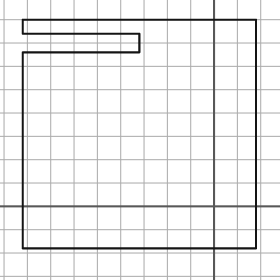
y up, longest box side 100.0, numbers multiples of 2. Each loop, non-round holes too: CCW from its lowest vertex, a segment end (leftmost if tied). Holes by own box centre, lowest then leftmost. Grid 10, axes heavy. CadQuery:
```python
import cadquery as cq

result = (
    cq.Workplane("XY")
    .moveTo(-82.0, -18.0)
    .lineTo(18.0, -18.0)
    .lineTo(18.0, 80.0)
    .lineTo(-82.0, 80.0)
    .lineTo(-82.0, 74.0)
    .lineTo(-32.0, 74.0)
    .lineTo(-32.0, 66.0)
    .lineTo(-82.0, 66.0)
    .close()
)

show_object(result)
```